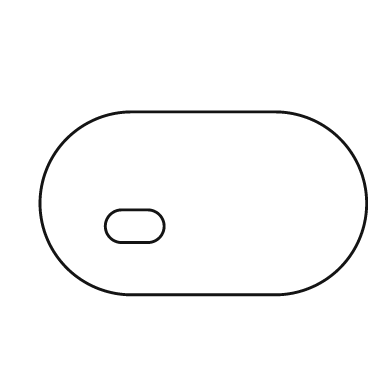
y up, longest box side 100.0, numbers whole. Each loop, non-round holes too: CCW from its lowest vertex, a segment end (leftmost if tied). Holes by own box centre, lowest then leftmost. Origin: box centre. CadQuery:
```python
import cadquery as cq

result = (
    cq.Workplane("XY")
    .moveTo(-22.0, -28.0)
    .lineTo(22.0, -28.0)
    .threePointArc((50.0, 0.0), (22.0, 28.0))
    .lineTo(-22.0, 28.0)
    .threePointArc((-50.0, 0.0), (-22.0, -28.0))
    .close()
    .moveTo(-25.0, -12.0)
    .lineTo(-17.0, -12.0)
    .threePointArc((-12.0, -7.0), (-17.0, -2.0))
    .lineTo(-25.0, -2.0)
    .threePointArc((-30.0, -7.0), (-25.0, -12.0))
    .close()
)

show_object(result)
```